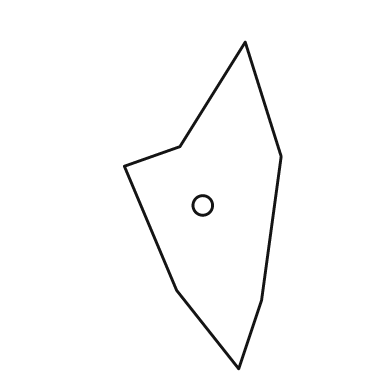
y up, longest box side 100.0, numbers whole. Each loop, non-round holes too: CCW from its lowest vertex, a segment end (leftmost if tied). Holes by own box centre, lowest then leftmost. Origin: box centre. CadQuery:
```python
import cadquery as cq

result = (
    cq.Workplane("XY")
    .moveTo(11.0, -50.0)
    .lineTo(18.0, -29.0)
    .lineTo(24.0, 15.0)
    .lineTo(13.0, 50.0)
    .lineTo(-7.0, 18.0)
    .lineTo(-24.0, 12.0)
    .lineTo(-8.0, -26.0)
    .close()
    .moveTo(0.0, 0.0)
    .circle(3.0)
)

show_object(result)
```